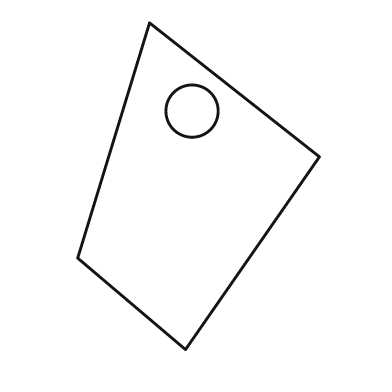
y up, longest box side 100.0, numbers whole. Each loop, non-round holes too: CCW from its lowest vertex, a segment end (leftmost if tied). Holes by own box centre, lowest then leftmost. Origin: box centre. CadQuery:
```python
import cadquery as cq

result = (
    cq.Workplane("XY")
    .moveTo(-4.0, -50.0)
    .lineTo(37.0, 9.0)
    .lineTo(-15.0, 50.0)
    .lineTo(-37.0, -22.0)
    .close()
    .moveTo(-2.0, 23.0)
    .circle(8.0)
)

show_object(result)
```